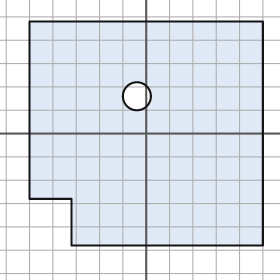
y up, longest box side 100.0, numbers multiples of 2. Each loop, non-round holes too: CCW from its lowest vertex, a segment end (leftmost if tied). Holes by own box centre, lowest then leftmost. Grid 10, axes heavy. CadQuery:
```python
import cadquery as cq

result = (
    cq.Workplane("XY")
    .moveTo(-32.0, -48.0)
    .lineTo(50.0, -48.0)
    .lineTo(50.0, 48.0)
    .lineTo(-50.0, 48.0)
    .lineTo(-50.0, -28.0)
    .lineTo(-32.0, -28.0)
    .close()
    .moveTo(-4.0, 16.0)
    .circle(6.0)
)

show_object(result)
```